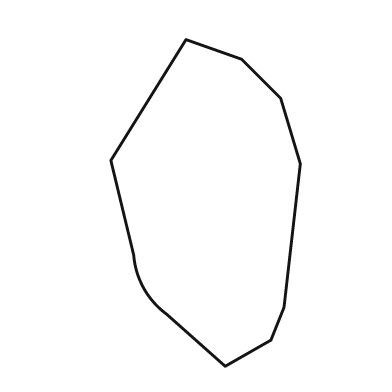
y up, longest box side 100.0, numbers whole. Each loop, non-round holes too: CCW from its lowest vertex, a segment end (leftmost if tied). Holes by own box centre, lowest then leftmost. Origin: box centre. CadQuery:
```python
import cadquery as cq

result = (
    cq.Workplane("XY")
    .moveTo(6.0, -50.0)
    .lineTo(20.0, -42.0)
    .lineTo(24.0, -32.0)
    .lineTo(29.0, 12.0)
    .lineTo(23.0, 32.0)
    .lineTo(11.0, 44.0)
    .lineTo(-6.0, 50.0)
    .lineTo(-29.0, 13.0)
    .lineTo(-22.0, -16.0)
    .threePointArc((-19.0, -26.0), (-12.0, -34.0))
    .close()
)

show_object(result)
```